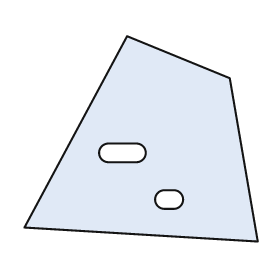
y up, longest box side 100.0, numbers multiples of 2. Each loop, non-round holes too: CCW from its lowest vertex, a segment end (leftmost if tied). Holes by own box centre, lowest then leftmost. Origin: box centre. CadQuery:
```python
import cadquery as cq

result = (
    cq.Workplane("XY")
    .moveTo(50.0, -44.0)
    .lineTo(38.0, 26.0)
    .lineTo(-6.0, 44.0)
    .lineTo(-50.0, -38.0)
    .close()
    .moveTo(10.0, -30.0)
    .lineTo(14.0, -30.0)
    .threePointArc((18.0, -26.0), (14.0, -22.0))
    .lineTo(10.0, -22.0)
    .threePointArc((6.0, -26.0), (10.0, -30.0))
    .close()
    .moveTo(-14.0, -10.0)
    .lineTo(-2.0, -10.0)
    .threePointArc((2.0, -6.0), (-2.0, -2.0))
    .lineTo(-14.0, -2.0)
    .threePointArc((-18.0, -6.0), (-14.0, -10.0))
    .close()
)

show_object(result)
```